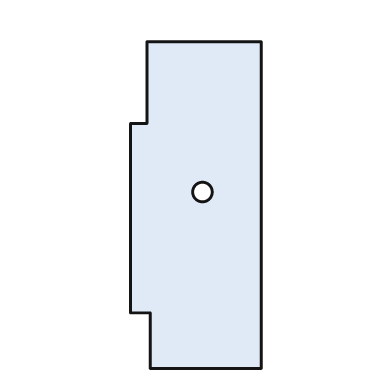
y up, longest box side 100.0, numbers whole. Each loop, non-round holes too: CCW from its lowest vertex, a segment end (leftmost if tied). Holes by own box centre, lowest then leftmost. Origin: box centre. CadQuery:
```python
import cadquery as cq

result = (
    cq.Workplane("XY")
    .moveTo(-14.0, -50.0)
    .lineTo(20.0, -50.0)
    .lineTo(20.0, 50.0)
    .lineTo(-15.0, 50.0)
    .lineTo(-15.0, 25.0)
    .lineTo(-20.0, 25.0)
    .lineTo(-20.0, -33.0)
    .lineTo(-14.0, -33.0)
    .close()
    .moveTo(2.0, 4.0)
    .circle(3.0)
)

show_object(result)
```